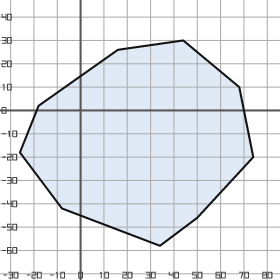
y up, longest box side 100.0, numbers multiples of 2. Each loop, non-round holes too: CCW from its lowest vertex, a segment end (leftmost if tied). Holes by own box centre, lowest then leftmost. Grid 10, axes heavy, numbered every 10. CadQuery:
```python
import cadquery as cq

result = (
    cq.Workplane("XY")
    .moveTo(34.0, -58.0)
    .lineTo(50.0, -46.0)
    .lineTo(74.0, -20.0)
    .lineTo(68.0, 10.0)
    .lineTo(44.0, 30.0)
    .lineTo(16.0, 26.0)
    .lineTo(-18.0, 2.0)
    .lineTo(-26.0, -18.0)
    .lineTo(-8.0, -42.0)
    .close()
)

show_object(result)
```